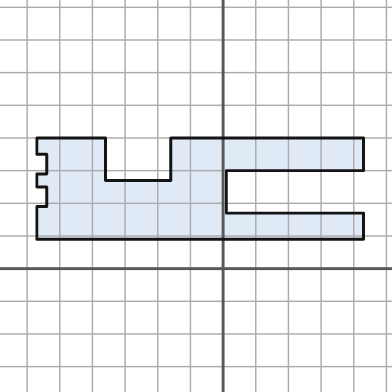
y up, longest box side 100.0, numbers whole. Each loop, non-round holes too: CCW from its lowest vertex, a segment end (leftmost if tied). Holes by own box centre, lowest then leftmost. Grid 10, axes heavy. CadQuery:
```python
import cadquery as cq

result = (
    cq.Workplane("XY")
    .moveTo(-57.0, 9.0)
    .lineTo(43.0, 9.0)
    .lineTo(43.0, 17.0)
    .lineTo(1.0, 17.0)
    .lineTo(1.0, 30.0)
    .lineTo(43.0, 30.0)
    .lineTo(43.0, 40.0)
    .lineTo(-16.0, 40.0)
    .lineTo(-16.0, 27.0)
    .lineTo(-36.0, 27.0)
    .lineTo(-36.0, 40.0)
    .lineTo(-57.0, 40.0)
    .lineTo(-57.0, 35.0)
    .lineTo(-54.0, 35.0)
    .lineTo(-54.0, 29.0)
    .lineTo(-57.0, 29.0)
    .lineTo(-57.0, 25.0)
    .lineTo(-54.0, 25.0)
    .lineTo(-54.0, 19.0)
    .lineTo(-57.0, 19.0)
    .close()
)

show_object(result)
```